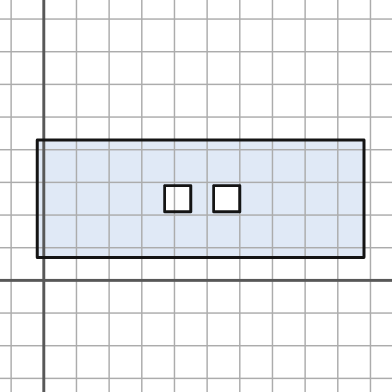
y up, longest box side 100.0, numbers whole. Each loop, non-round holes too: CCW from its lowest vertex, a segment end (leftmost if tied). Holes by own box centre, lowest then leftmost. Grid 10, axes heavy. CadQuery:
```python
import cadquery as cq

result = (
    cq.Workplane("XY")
    .moveTo(-2.0, 7.0)
    .lineTo(98.0, 7.0)
    .lineTo(98.0, 43.0)
    .lineTo(-2.0, 43.0)
    .close()
    .moveTo(37.0, 21.0)
    .lineTo(45.0, 21.0)
    .lineTo(45.0, 29.0)
    .lineTo(37.0, 29.0)
    .close()
    .moveTo(52.0, 21.0)
    .lineTo(60.0, 21.0)
    .lineTo(60.0, 29.0)
    .lineTo(52.0, 29.0)
    .close()
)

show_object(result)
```